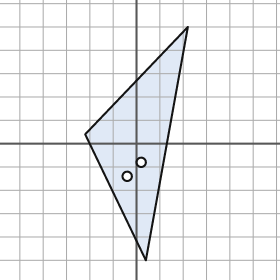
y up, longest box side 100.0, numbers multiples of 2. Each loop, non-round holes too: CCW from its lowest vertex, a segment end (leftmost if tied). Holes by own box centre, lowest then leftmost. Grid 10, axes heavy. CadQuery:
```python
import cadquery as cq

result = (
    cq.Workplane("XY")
    .moveTo(4.0, -50.0)
    .lineTo(22.0, 50.0)
    .lineTo(-22.0, 4.0)
    .close()
    .moveTo(-4.0, -14.0)
    .circle(2.0)
    .moveTo(2.0, -8.0)
    .circle(2.0)
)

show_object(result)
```